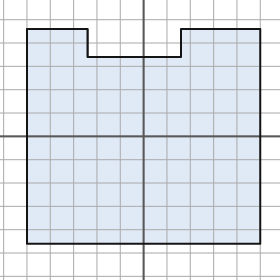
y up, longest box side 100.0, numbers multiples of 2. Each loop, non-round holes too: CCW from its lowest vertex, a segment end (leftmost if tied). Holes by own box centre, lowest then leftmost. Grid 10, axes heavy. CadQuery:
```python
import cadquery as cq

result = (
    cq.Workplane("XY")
    .moveTo(-50.0, -46.0)
    .lineTo(50.0, -46.0)
    .lineTo(50.0, 46.0)
    .lineTo(16.0, 46.0)
    .lineTo(16.0, 34.0)
    .lineTo(-24.0, 34.0)
    .lineTo(-24.0, 46.0)
    .lineTo(-50.0, 46.0)
    .close()
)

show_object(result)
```